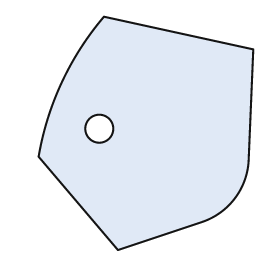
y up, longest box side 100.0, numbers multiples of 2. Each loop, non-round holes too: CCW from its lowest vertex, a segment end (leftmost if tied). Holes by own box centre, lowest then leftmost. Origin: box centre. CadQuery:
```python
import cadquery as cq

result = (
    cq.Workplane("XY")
    .moveTo(-12.0, -50.0)
    .lineTo(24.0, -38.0)
    .threePointArc((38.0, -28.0), (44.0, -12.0))
    .lineTo(46.0, 36.0)
    .lineTo(-18.0, 50.0)
    .threePointArc((-36.0, 22.0), (-46.0, -10.0))
    .close()
    .moveTo(-20.0, 2.0)
    .circle(6.0)
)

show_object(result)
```